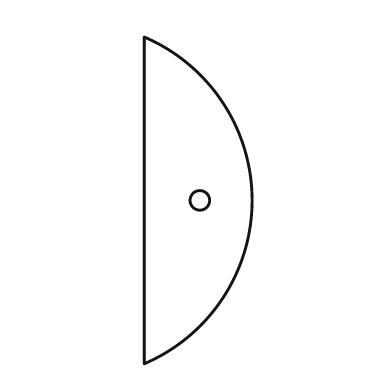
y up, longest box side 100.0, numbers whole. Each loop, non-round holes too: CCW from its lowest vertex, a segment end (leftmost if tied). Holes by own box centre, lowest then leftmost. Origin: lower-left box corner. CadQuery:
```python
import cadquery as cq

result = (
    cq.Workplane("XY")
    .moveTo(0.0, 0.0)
    .threePointArc((33.0, 50.0), (0.0, 100.0))
    .close()
    .moveTo(17.0, 50.0)
    .circle(3.0)
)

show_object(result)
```